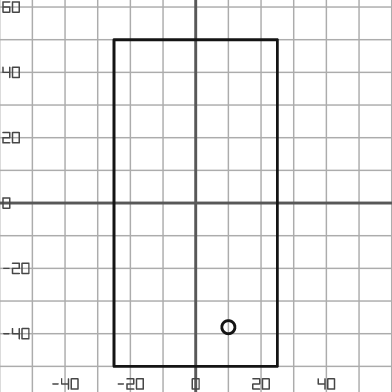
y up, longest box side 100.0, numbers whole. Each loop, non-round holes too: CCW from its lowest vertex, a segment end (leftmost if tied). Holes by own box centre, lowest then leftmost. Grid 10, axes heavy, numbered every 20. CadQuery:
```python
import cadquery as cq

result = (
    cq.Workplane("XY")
    .moveTo(-25.0, -50.0)
    .lineTo(25.0, -50.0)
    .lineTo(25.0, 50.0)
    .lineTo(-25.0, 50.0)
    .close()
    .moveTo(10.0, -38.0)
    .circle(2.0)
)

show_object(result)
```